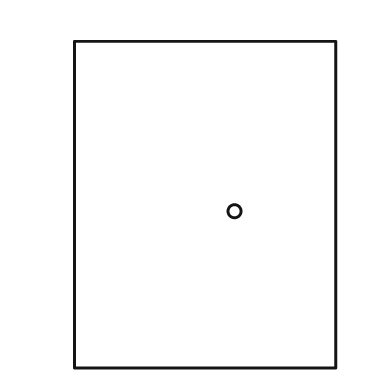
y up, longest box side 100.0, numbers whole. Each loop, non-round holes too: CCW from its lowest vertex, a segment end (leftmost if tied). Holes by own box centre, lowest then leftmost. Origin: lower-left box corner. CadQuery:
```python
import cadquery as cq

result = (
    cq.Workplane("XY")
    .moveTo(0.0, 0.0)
    .lineTo(80.0, 0.0)
    .lineTo(80.0, 100.0)
    .lineTo(0.0, 100.0)
    .close()
    .moveTo(49.0, 48.0)
    .circle(2.0)
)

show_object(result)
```